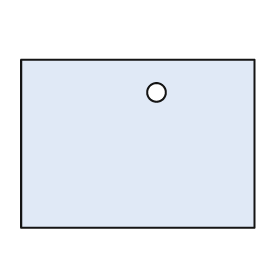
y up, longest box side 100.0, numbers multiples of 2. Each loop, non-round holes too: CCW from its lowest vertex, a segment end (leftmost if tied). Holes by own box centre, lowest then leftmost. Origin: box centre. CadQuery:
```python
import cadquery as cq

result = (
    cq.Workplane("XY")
    .moveTo(-50.0, -36.0)
    .lineTo(50.0, -36.0)
    .lineTo(50.0, 36.0)
    .lineTo(-50.0, 36.0)
    .close()
    .moveTo(8.0, 22.0)
    .circle(4.0)
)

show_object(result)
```